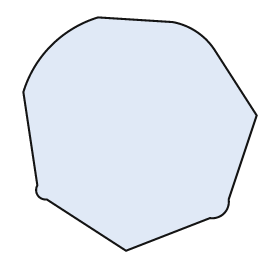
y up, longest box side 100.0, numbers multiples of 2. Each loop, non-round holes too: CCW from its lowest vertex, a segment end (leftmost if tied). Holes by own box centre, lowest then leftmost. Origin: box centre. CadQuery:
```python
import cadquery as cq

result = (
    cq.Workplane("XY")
    .moveTo(-6.0, -50.0)
    .lineTo(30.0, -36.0)
    .threePointArc((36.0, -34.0), (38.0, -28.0))
    .lineTo(50.0, 8.0)
    .lineTo(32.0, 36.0)
    .threePointArc((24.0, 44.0), (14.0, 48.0))
    .lineTo(-18.0, 50.0)
    .threePointArc((-38.0, 38.0), (-50.0, 18.0))
    .lineTo(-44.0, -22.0)
    .threePointArc((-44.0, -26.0), (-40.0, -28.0))
    .close()
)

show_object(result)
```